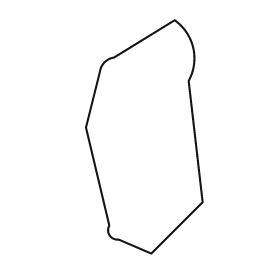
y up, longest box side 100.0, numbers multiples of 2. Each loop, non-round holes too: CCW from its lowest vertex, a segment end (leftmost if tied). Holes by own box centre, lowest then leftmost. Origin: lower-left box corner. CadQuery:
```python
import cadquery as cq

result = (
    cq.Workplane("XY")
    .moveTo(28.0, 0.0)
    .lineTo(50.0, 22.0)
    .lineTo(44.0, 74.0)
    .threePointArc((46.0, 88.0), (38.0, 100.0))
    .lineTo(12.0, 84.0)
    .threePointArc((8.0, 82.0), (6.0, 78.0))
    .lineTo(0.0, 54.0)
    .lineTo(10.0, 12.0)
    .threePointArc((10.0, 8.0), (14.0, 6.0))
    .close()
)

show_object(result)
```